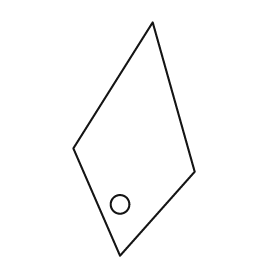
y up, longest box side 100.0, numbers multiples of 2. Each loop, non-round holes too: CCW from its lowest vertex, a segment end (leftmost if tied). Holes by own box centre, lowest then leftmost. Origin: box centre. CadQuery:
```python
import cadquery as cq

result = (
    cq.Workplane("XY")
    .moveTo(-6.0, -50.0)
    .lineTo(26.0, -14.0)
    .lineTo(8.0, 50.0)
    .lineTo(-26.0, -4.0)
    .close()
    .moveTo(-6.0, -28.0)
    .circle(4.0)
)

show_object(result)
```